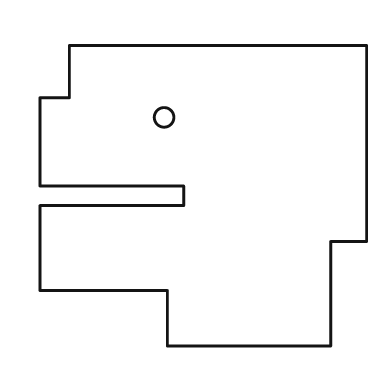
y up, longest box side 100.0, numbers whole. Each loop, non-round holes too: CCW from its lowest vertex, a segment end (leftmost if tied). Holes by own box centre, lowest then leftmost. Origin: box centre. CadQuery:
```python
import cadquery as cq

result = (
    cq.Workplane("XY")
    .moveTo(-11.0, -46.0)
    .lineTo(39.0, -46.0)
    .lineTo(39.0, -14.0)
    .lineTo(50.0, -14.0)
    .lineTo(50.0, 46.0)
    .lineTo(-41.0, 46.0)
    .lineTo(-41.0, 30.0)
    .lineTo(-50.0, 30.0)
    .lineTo(-50.0, 3.0)
    .lineTo(-6.0, 3.0)
    .lineTo(-6.0, -3.0)
    .lineTo(-50.0, -3.0)
    .lineTo(-50.0, -29.0)
    .lineTo(-11.0, -29.0)
    .close()
    .moveTo(-12.0, 24.0)
    .circle(3.0)
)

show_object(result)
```